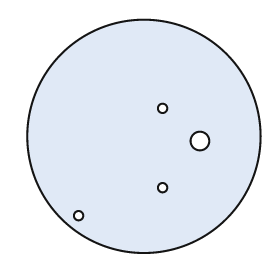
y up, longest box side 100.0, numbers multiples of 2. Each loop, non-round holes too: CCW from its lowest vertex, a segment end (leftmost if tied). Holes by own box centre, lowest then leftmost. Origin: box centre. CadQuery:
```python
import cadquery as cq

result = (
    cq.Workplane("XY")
    .moveTo(0.0, 0.0)
    .circle(50.0)
    .moveTo(-28.0, -34.0)
    .circle(2.0)
    .moveTo(8.0, -22.0)
    .circle(2.0)
    .moveTo(24.0, -2.0)
    .circle(4.0)
    .moveTo(8.0, 12.0)
    .circle(2.0)
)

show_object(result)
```